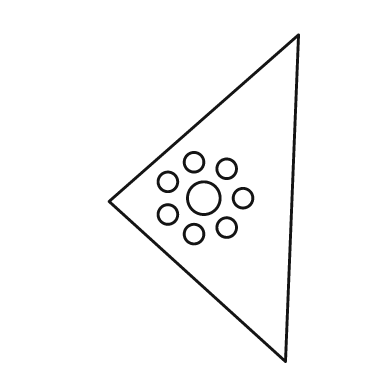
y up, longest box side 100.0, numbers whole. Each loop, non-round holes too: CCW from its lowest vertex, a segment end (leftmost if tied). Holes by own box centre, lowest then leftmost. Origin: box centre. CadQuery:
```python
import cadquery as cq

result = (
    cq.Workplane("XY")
    .moveTo(25.0, -50.0)
    .lineTo(29.0, 50.0)
    .lineTo(-29.0, -1.0)
    .close()
    .moveTo(-3.0, -11.0)
    .circle(3.0)
    .moveTo(7.0, -9.0)
    .circle(3.0)
    .moveTo(-11.0, -5.0)
    .circle(3.0)
    .moveTo(0.0, 0.0)
    .circle(5.0)
    .moveTo(12.0, 0.0)
    .circle(3.0)
    .moveTo(-11.0, 5.0)
    .circle(3.0)
    .moveTo(7.0, 9.0)
    .circle(3.0)
    .moveTo(-3.0, 11.0)
    .circle(3.0)
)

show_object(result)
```